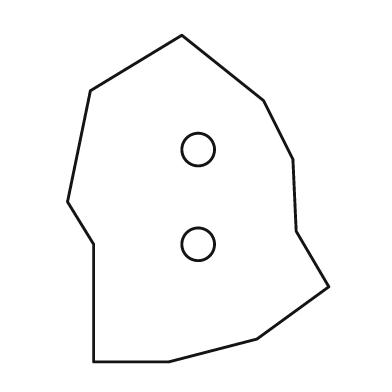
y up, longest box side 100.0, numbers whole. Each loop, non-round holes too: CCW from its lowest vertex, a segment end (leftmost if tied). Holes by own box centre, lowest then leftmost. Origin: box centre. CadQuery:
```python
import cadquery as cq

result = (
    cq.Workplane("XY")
    .moveTo(-32.0, -50.0)
    .lineTo(-9.0, -50.0)
    .lineTo(18.0, -43.0)
    .lineTo(40.0, -27.0)
    .lineTo(30.0, -10.0)
    .lineTo(29.0, 12.0)
    .lineTo(20.0, 30.0)
    .lineTo(-5.0, 50.0)
    .lineTo(-33.0, 33.0)
    .lineTo(-40.0, -1.0)
    .lineTo(-32.0, -14.0)
    .close()
    .moveTo(0.0, -14.0)
    .circle(5.0)
    .moveTo(0.0, 15.0)
    .circle(5.0)
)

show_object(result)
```